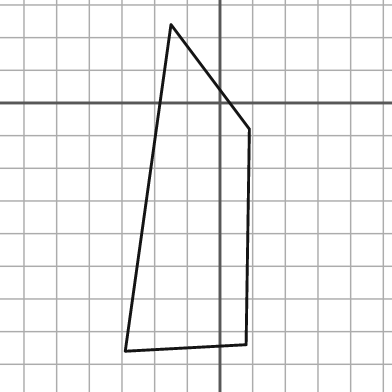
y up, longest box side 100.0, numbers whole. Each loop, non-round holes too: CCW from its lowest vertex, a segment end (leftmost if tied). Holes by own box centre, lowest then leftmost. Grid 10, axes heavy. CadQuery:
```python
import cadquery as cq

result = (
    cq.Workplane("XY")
    .moveTo(-29.0, -76.0)
    .lineTo(8.0, -74.0)
    .lineTo(9.0, -8.0)
    .lineTo(-15.0, 24.0)
    .close()
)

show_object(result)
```